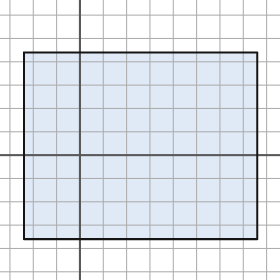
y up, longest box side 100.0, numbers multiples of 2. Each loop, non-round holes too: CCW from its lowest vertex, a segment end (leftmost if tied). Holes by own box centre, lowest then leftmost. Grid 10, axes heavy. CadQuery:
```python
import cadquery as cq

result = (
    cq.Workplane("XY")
    .moveTo(-24.0, -36.0)
    .lineTo(76.0, -36.0)
    .lineTo(76.0, 44.0)
    .lineTo(-24.0, 44.0)
    .close()
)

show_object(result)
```